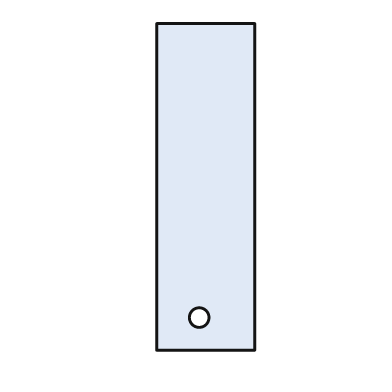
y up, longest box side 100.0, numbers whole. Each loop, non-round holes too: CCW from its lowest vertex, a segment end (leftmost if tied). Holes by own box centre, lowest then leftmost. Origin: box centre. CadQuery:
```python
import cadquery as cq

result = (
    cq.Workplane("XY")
    .moveTo(-15.0, -50.0)
    .lineTo(15.0, -50.0)
    .lineTo(15.0, 50.0)
    .lineTo(-15.0, 50.0)
    .close()
    .moveTo(-2.0, -40.0)
    .circle(3.0)
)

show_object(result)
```